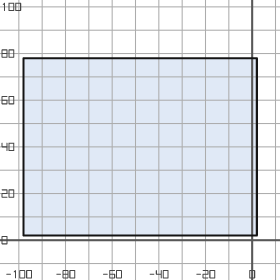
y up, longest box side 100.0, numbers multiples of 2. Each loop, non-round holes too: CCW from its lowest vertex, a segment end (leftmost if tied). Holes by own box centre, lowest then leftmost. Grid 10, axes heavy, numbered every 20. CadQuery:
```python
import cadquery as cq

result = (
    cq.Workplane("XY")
    .moveTo(-98.0, 2.0)
    .lineTo(2.0, 2.0)
    .lineTo(2.0, 78.0)
    .lineTo(-98.0, 78.0)
    .close()
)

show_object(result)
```